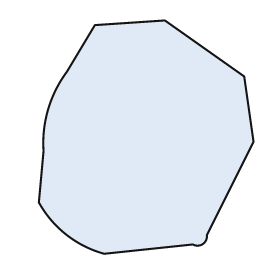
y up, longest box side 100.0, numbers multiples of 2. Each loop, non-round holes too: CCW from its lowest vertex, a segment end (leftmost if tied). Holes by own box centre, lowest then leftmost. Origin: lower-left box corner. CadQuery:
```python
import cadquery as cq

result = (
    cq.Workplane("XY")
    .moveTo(28.0, 0.0)
    .lineTo(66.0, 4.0)
    .threePointArc((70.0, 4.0), (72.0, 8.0))
    .lineTo(92.0, 48.0)
    .lineTo(88.0, 76.0)
    .lineTo(54.0, 100.0)
    .lineTo(24.0, 98.0)
    .lineTo(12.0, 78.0)
    .threePointArc((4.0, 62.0), (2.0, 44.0))
    .lineTo(0.0, 22.0)
    .threePointArc((12.0, 8.0), (28.0, 0.0))
    .close()
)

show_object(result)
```